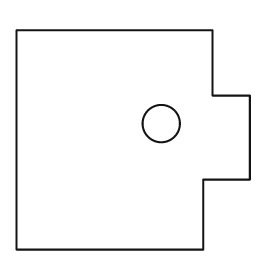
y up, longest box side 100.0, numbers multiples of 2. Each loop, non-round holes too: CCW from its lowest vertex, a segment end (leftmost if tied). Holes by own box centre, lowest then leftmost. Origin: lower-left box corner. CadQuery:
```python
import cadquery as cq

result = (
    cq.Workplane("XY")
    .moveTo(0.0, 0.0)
    .lineTo(80.0, 0.0)
    .lineTo(80.0, 30.0)
    .lineTo(100.0, 30.0)
    .lineTo(100.0, 66.0)
    .lineTo(84.0, 66.0)
    .lineTo(84.0, 94.0)
    .lineTo(0.0, 94.0)
    .close()
    .moveTo(62.0, 54.0)
    .circle(8.0)
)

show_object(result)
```